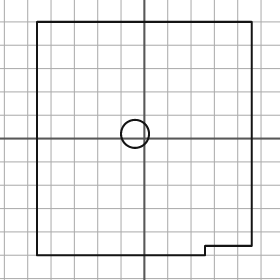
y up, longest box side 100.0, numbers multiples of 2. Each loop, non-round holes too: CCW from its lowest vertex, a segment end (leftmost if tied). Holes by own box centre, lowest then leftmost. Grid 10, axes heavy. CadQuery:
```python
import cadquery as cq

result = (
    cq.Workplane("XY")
    .moveTo(-46.0, -50.0)
    .lineTo(26.0, -50.0)
    .lineTo(26.0, -46.0)
    .lineTo(46.0, -46.0)
    .lineTo(46.0, 50.0)
    .lineTo(-46.0, 50.0)
    .close()
    .moveTo(-4.0, 2.0)
    .circle(6.0)
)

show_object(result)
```